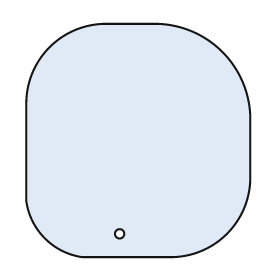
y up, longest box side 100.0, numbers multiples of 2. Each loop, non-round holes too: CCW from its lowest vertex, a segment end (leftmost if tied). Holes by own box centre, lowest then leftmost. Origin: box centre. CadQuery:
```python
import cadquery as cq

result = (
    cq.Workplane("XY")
    .moveTo(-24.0, -50.0)
    .lineTo(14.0, -50.0)
    .threePointArc((38.0, -40.0), (48.0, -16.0))
    .lineTo(48.0, 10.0)
    .threePointArc((36.0, 38.0), (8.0, 50.0))
    .lineTo(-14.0, 50.0)
    .threePointArc((-38.0, 40.0), (-48.0, 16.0))
    .lineTo(-48.0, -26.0)
    .threePointArc((-40.0, -42.0), (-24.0, -50.0))
    .close()
    .moveTo(-8.0, -40.0)
    .circle(2.0)
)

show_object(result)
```